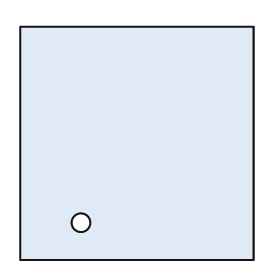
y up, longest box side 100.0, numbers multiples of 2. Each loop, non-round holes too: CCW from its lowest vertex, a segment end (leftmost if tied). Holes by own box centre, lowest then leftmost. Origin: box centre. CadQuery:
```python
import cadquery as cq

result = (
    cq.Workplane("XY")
    .moveTo(-50.0, -50.0)
    .lineTo(50.0, -50.0)
    .lineTo(50.0, 50.0)
    .lineTo(-50.0, 50.0)
    .close()
    .moveTo(-24.0, -34.0)
    .circle(4.0)
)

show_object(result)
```